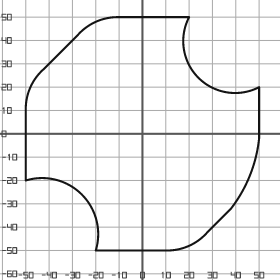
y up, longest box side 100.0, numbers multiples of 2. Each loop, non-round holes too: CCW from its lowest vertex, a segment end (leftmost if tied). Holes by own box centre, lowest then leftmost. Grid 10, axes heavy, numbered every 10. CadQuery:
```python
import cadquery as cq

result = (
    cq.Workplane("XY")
    .moveTo(-20.0, -50.0)
    .lineTo(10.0, -50.0)
    .threePointArc((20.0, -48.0), (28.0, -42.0))
    .lineTo(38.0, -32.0)
    .threePointArc((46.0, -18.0), (50.0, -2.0))
    .lineTo(50.0, 20.0)
    .threePointArc((24.0, 24.0), (20.0, 50.0))
    .lineTo(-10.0, 50.0)
    .threePointArc((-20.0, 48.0), (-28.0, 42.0))
    .lineTo(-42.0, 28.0)
    .threePointArc((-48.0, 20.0), (-50.0, 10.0))
    .lineTo(-50.0, -20.0)
    .threePointArc((-26.0, -26.0), (-20.0, -50.0))
    .close()
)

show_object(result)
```